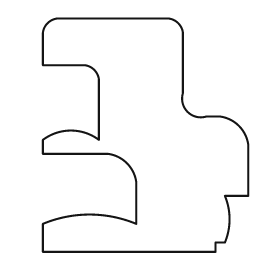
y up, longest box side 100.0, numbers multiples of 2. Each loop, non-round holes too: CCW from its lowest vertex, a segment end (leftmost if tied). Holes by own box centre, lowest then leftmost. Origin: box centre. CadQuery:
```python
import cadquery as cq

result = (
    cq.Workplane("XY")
    .moveTo(-44.0, -50.0)
    .lineTo(30.0, -50.0)
    .lineTo(30.0, -46.0)
    .lineTo(34.0, -46.0)
    .threePointArc((36.0, -36.0), (34.0, -26.0))
    .lineTo(44.0, -26.0)
    .lineTo(44.0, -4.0)
    .threePointArc((40.0, 4.0), (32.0, 8.0))
    .lineTo(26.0, 8.0)
    .threePointArc((18.0, 10.0), (16.0, 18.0))
    .lineTo(16.0, 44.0)
    .threePointArc((14.0, 48.0), (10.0, 50.0))
    .lineTo(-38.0, 50.0)
    .threePointArc((-42.0, 48.0), (-44.0, 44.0))
    .lineTo(-44.0, 30.0)
    .lineTo(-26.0, 30.0)
    .threePointArc((-22.0, 28.0), (-20.0, 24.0))
    .lineTo(-20.0, -2.0)
    .threePointArc((-32.0, 2.0), (-44.0, -2.0))
    .lineTo(-44.0, -8.0)
    .lineTo(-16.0, -8.0)
    .threePointArc((-8.0, -12.0), (-4.0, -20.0))
    .lineTo(-4.0, -38.0)
    .threePointArc((-24.0, -34.0), (-44.0, -38.0))
    .close()
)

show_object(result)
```